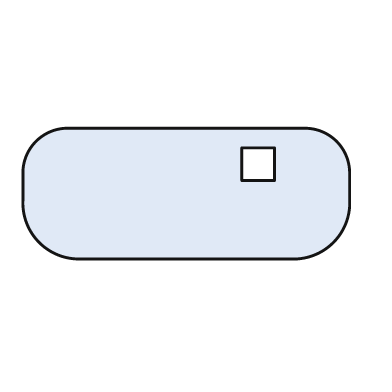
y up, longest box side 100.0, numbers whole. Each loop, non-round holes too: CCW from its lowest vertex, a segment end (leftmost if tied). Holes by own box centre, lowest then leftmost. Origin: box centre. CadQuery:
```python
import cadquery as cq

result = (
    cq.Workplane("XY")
    .moveTo(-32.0, -20.0)
    .lineTo(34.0, -20.0)
    .threePointArc((45.0, -15.0), (50.0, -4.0))
    .lineTo(50.0, 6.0)
    .threePointArc((46.0, 16.0), (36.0, 20.0))
    .lineTo(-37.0, 20.0)
    .threePointArc((-46.0, 16.0), (-50.0, 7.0))
    .lineTo(-50.0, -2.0)
    .threePointArc((-45.0, -15.0), (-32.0, -20.0))
    .close()
    .moveTo(17.0, 4.0)
    .lineTo(27.0, 4.0)
    .lineTo(27.0, 14.0)
    .lineTo(17.0, 14.0)
    .close()
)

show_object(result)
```